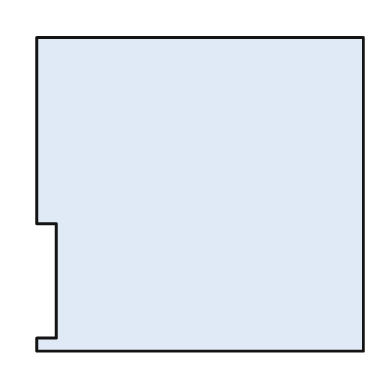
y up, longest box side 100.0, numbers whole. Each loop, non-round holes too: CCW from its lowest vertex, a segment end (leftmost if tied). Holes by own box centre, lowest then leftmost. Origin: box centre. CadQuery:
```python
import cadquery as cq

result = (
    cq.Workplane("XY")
    .moveTo(-50.0, -48.0)
    .lineTo(50.0, -48.0)
    .lineTo(50.0, 48.0)
    .lineTo(-50.0, 48.0)
    .lineTo(-50.0, -9.0)
    .lineTo(-44.0, -9.0)
    .lineTo(-44.0, -44.0)
    .lineTo(-50.0, -44.0)
    .close()
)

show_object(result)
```